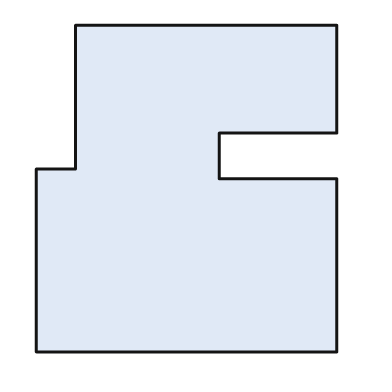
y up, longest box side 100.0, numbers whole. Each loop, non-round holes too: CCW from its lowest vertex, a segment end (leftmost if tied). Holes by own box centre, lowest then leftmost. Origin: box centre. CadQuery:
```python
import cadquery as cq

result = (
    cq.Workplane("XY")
    .moveTo(-46.0, -50.0)
    .lineTo(46.0, -50.0)
    .lineTo(46.0, 3.0)
    .lineTo(10.0, 3.0)
    .lineTo(10.0, 17.0)
    .lineTo(46.0, 17.0)
    .lineTo(46.0, 50.0)
    .lineTo(-34.0, 50.0)
    .lineTo(-34.0, 6.0)
    .lineTo(-46.0, 6.0)
    .close()
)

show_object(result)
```